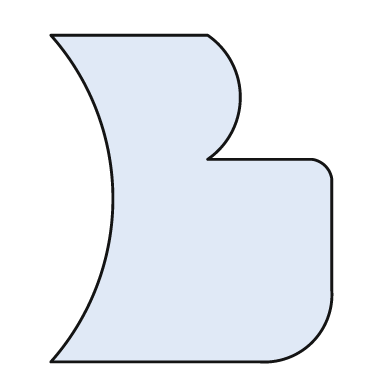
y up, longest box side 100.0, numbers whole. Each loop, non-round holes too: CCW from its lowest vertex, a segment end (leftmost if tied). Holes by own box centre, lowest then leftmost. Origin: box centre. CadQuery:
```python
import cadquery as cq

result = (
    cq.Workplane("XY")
    .moveTo(-43.0, -50.0)
    .lineTo(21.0, -50.0)
    .threePointArc((37.0, -44.0), (43.0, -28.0))
    .lineTo(43.0, 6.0)
    .threePointArc((41.0, 10.0), (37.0, 12.0))
    .lineTo(5.0, 12.0)
    .threePointArc((15.0, 31.0), (5.0, 50.0))
    .lineTo(-43.0, 50.0)
    .threePointArc((-24.0, 0.0), (-43.0, -50.0))
    .close()
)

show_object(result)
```